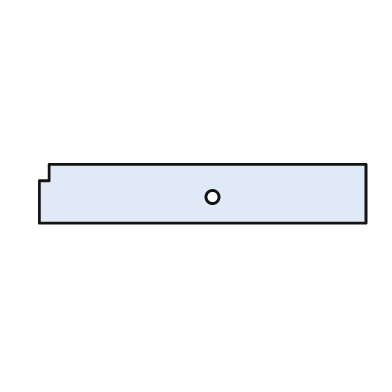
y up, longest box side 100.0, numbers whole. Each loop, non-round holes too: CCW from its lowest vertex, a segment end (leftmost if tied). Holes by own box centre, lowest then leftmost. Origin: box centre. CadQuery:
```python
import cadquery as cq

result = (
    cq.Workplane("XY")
    .moveTo(-50.0, -9.0)
    .lineTo(50.0, -9.0)
    .lineTo(50.0, 9.0)
    .lineTo(-47.0, 9.0)
    .lineTo(-47.0, 4.0)
    .lineTo(-50.0, 4.0)
    .close()
    .moveTo(3.0, -1.0)
    .circle(2.0)
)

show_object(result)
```